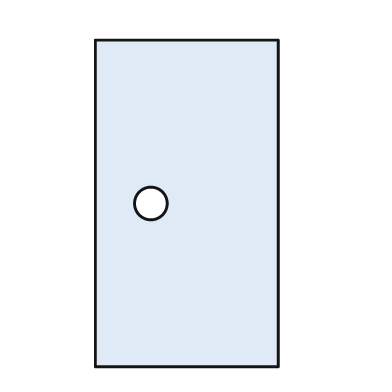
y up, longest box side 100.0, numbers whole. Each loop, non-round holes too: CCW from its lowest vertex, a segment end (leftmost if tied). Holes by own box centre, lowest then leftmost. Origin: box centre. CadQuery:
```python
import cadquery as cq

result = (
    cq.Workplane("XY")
    .moveTo(-28.0, -50.0)
    .lineTo(28.0, -50.0)
    .lineTo(28.0, 50.0)
    .lineTo(-28.0, 50.0)
    .close()
    .moveTo(-11.0, 0.0)
    .circle(5.0)
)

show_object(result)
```